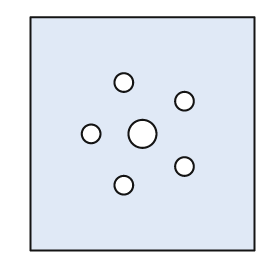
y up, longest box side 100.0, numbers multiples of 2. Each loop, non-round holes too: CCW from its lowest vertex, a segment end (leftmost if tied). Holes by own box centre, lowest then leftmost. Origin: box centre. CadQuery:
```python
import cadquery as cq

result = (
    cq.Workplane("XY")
    .moveTo(-48.0, -50.0)
    .lineTo(48.0, -50.0)
    .lineTo(48.0, 50.0)
    .lineTo(-48.0, 50.0)
    .close()
    .moveTo(-8.0, -22.0)
    .circle(4.0)
    .moveTo(18.0, -14.0)
    .circle(4.0)
    .moveTo(-22.0, 0.0)
    .circle(4.0)
    .moveTo(0.0, 0.0)
    .circle(6.0)
    .moveTo(18.0, 14.0)
    .circle(4.0)
    .moveTo(-8.0, 22.0)
    .circle(4.0)
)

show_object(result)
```